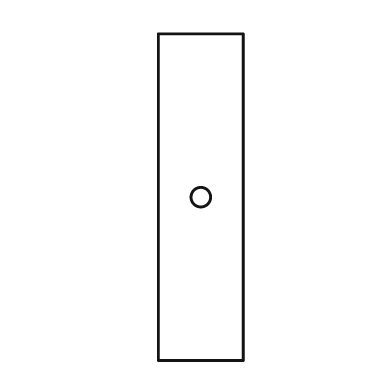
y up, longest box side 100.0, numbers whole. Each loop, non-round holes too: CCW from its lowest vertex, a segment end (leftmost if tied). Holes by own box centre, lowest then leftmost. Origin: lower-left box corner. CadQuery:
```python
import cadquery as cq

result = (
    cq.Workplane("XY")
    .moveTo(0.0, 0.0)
    .lineTo(26.0, 0.0)
    .lineTo(26.0, 100.0)
    .lineTo(0.0, 100.0)
    .close()
    .moveTo(13.0, 50.0)
    .circle(3.0)
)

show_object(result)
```